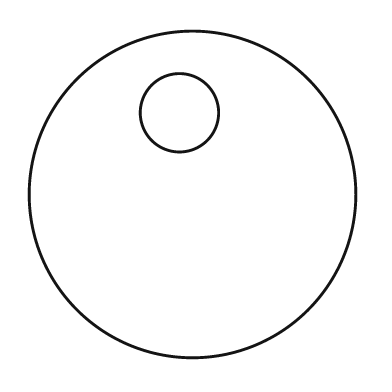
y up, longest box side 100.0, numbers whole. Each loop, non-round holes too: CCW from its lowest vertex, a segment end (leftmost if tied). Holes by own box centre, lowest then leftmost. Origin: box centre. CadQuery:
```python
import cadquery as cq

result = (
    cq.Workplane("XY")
    .moveTo(0.0, 0.0)
    .circle(50.0)
    .moveTo(-4.0, 25.0)
    .circle(12.0)
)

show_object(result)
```